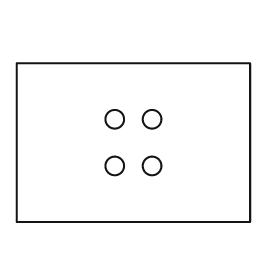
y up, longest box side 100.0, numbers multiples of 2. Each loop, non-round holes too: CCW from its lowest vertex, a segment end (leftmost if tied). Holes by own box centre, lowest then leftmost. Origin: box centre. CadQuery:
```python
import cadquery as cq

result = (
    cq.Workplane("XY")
    .moveTo(-50.0, -34.0)
    .lineTo(50.0, -34.0)
    .lineTo(50.0, 34.0)
    .lineTo(-50.0, 34.0)
    .close()
    .moveTo(-8.0, -10.0)
    .circle(4.0)
    .moveTo(8.0, -10.0)
    .circle(4.0)
    .moveTo(-8.0, 10.0)
    .circle(4.0)
    .moveTo(8.0, 10.0)
    .circle(4.0)
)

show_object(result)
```